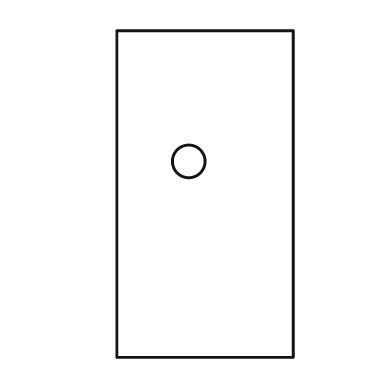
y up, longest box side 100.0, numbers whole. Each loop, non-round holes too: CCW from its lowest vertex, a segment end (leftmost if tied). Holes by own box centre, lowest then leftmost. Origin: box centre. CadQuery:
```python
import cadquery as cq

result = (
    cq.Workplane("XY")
    .moveTo(-27.0, -50.0)
    .lineTo(27.0, -50.0)
    .lineTo(27.0, 50.0)
    .lineTo(-27.0, 50.0)
    .close()
    .moveTo(-5.0, 10.0)
    .circle(5.0)
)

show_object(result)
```